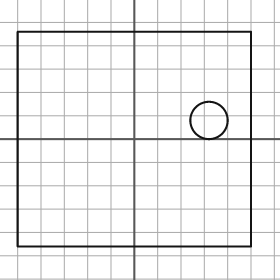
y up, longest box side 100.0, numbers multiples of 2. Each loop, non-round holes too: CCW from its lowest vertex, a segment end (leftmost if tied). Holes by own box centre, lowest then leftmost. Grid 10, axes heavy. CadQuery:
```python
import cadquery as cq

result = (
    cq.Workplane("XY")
    .moveTo(-50.0, -46.0)
    .lineTo(50.0, -46.0)
    .lineTo(50.0, 46.0)
    .lineTo(-50.0, 46.0)
    .close()
    .moveTo(32.0, 8.0)
    .circle(8.0)
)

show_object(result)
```